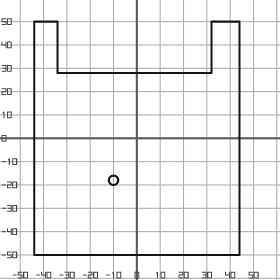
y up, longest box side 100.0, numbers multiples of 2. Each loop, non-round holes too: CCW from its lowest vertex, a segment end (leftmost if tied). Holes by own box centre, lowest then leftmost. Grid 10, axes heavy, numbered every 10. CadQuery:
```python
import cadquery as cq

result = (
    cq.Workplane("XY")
    .moveTo(-44.0, -50.0)
    .lineTo(44.0, -50.0)
    .lineTo(44.0, 50.0)
    .lineTo(32.0, 50.0)
    .lineTo(32.0, 28.0)
    .lineTo(-34.0, 28.0)
    .lineTo(-34.0, 50.0)
    .lineTo(-44.0, 50.0)
    .close()
    .moveTo(-10.0, -18.0)
    .circle(2.0)
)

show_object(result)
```